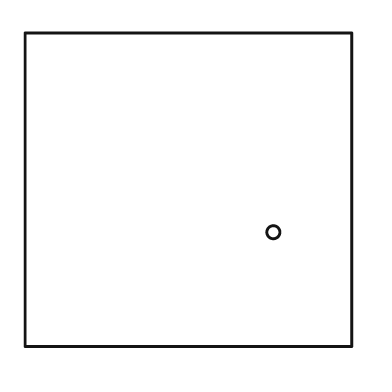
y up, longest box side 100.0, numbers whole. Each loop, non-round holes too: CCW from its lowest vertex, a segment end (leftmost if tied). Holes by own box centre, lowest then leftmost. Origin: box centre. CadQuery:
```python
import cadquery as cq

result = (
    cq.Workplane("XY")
    .moveTo(-50.0, -48.0)
    .lineTo(50.0, -48.0)
    .lineTo(50.0, 48.0)
    .lineTo(-50.0, 48.0)
    .close()
    .moveTo(26.0, -13.0)
    .circle(2.0)
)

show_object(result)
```